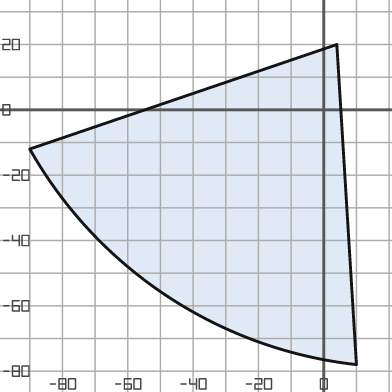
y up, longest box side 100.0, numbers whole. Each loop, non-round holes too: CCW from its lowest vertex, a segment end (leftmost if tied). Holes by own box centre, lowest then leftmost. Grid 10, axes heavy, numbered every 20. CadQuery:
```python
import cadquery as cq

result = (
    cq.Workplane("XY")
    .moveTo(10.0, -78.0)
    .lineTo(4.0, 20.0)
    .lineTo(-90.0, -12.0)
    .threePointArc((-48.0, -57.0), (10.0, -78.0))
    .close()
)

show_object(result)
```